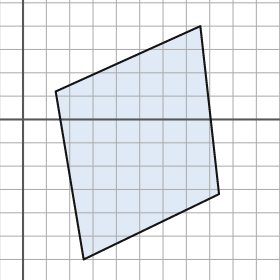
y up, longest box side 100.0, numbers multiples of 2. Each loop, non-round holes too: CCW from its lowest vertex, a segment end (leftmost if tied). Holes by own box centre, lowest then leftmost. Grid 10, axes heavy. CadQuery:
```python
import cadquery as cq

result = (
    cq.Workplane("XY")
    .moveTo(26.0, -60.0)
    .lineTo(84.0, -32.0)
    .lineTo(76.0, 40.0)
    .lineTo(14.0, 12.0)
    .close()
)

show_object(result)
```